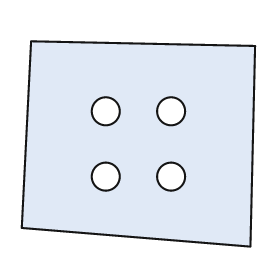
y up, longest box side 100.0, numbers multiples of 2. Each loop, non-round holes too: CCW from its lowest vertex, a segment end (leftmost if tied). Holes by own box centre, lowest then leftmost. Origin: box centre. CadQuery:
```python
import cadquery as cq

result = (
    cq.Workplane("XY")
    .moveTo(48.0, -44.0)
    .lineTo(50.0, 42.0)
    .lineTo(-46.0, 44.0)
    .lineTo(-50.0, -36.0)
    .close()
    .moveTo(-14.0, -14.0)
    .circle(6.0)
    .moveTo(14.0, -14.0)
    .circle(6.0)
    .moveTo(-14.0, 14.0)
    .circle(6.0)
    .moveTo(14.0, 14.0)
    .circle(6.0)
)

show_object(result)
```